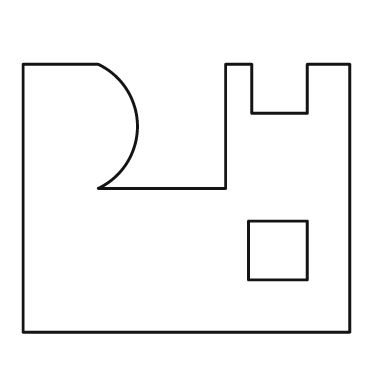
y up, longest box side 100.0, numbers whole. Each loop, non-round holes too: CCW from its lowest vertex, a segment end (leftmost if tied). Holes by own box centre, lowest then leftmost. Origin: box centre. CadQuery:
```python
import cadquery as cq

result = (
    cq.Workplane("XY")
    .moveTo(-50.0, -41.0)
    .lineTo(50.0, -41.0)
    .lineTo(50.0, 41.0)
    .lineTo(37.0, 41.0)
    .lineTo(37.0, 26.0)
    .lineTo(20.0, 26.0)
    .lineTo(20.0, 41.0)
    .lineTo(12.0, 41.0)
    .lineTo(12.0, 3.0)
    .lineTo(-27.0, 3.0)
    .threePointArc((-15.0, 22.0), (-27.0, 41.0))
    .lineTo(-50.0, 41.0)
    .close()
    .moveTo(19.0, -25.0)
    .lineTo(37.0, -25.0)
    .lineTo(37.0, -7.0)
    .lineTo(19.0, -7.0)
    .close()
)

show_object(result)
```